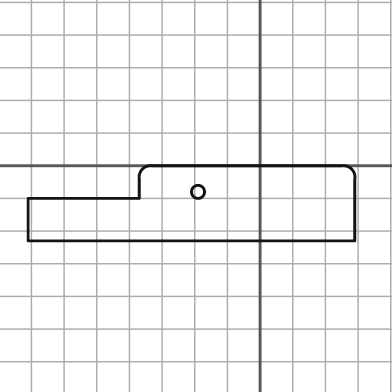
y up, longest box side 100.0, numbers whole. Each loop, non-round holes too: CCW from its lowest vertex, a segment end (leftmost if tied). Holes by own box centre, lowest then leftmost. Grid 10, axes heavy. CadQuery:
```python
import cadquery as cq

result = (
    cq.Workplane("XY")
    .moveTo(-71.0, -23.0)
    .lineTo(29.0, -23.0)
    .lineTo(29.0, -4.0)
    .threePointArc((28.0, -1.0), (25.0, 0.0))
    .lineTo(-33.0, 0.0)
    .threePointArc((-36.0, -1.0), (-37.0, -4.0))
    .lineTo(-37.0, -10.0)
    .lineTo(-71.0, -10.0)
    .close()
    .moveTo(-19.0, -8.0)
    .circle(2.0)
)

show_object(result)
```